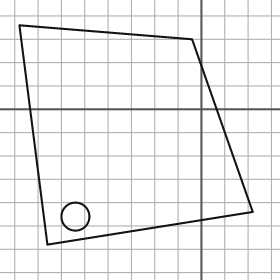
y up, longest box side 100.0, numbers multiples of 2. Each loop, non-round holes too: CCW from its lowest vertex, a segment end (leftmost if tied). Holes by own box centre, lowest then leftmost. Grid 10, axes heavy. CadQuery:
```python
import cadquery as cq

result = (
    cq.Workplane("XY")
    .moveTo(-66.0, -58.0)
    .lineTo(22.0, -44.0)
    .lineTo(-4.0, 30.0)
    .lineTo(-78.0, 36.0)
    .close()
    .moveTo(-54.0, -46.0)
    .circle(6.0)
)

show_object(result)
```